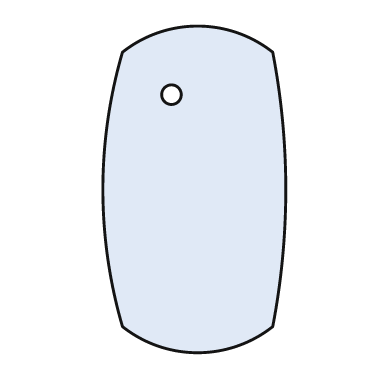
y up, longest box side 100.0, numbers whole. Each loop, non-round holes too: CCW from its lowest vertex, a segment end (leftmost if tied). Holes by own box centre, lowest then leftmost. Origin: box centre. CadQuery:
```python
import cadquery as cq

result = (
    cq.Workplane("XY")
    .moveTo(-22.0, -42.0)
    .threePointArc((1.0, -50.0), (24.0, -42.0))
    .threePointArc((28.0, 0.0), (24.0, 42.0))
    .threePointArc((1.0, 50.0), (-22.0, 42.0))
    .threePointArc((-28.0, 0.0), (-22.0, -42.0))
    .close()
    .moveTo(-7.0, 29.0)
    .circle(3.0)
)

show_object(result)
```